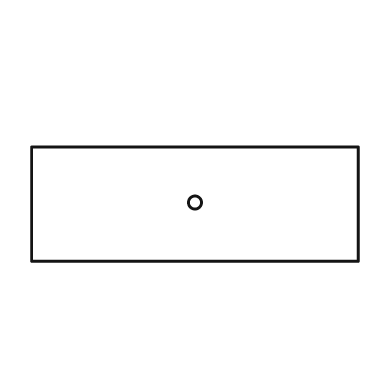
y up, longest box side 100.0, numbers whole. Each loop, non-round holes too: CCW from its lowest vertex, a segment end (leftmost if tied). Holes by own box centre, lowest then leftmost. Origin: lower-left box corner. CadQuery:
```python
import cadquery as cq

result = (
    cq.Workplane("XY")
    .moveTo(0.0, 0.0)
    .lineTo(100.0, 0.0)
    .lineTo(100.0, 35.0)
    .lineTo(0.0, 35.0)
    .close()
    .moveTo(50.0, 18.0)
    .circle(2.0)
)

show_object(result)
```